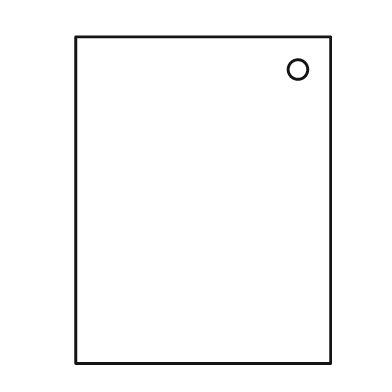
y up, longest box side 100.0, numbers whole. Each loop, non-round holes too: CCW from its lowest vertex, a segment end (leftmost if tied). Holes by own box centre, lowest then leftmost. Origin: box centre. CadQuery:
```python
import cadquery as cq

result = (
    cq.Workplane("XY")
    .moveTo(-39.0, -50.0)
    .lineTo(39.0, -50.0)
    .lineTo(39.0, 50.0)
    .lineTo(-39.0, 50.0)
    .close()
    .moveTo(29.0, 40.0)
    .circle(3.0)
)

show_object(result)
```